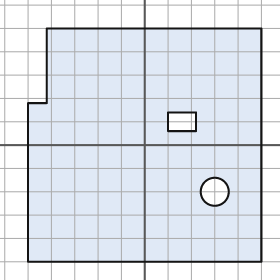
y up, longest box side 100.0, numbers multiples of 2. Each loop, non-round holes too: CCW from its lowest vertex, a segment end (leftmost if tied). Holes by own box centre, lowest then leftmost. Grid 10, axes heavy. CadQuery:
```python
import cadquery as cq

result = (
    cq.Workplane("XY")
    .moveTo(-50.0, -50.0)
    .lineTo(50.0, -50.0)
    .lineTo(50.0, 50.0)
    .lineTo(-42.0, 50.0)
    .lineTo(-42.0, 18.0)
    .lineTo(-50.0, 18.0)
    .close()
    .moveTo(30.0, -20.0)
    .circle(6.0)
    .moveTo(10.0, 6.0)
    .lineTo(22.0, 6.0)
    .lineTo(22.0, 14.0)
    .lineTo(10.0, 14.0)
    .close()
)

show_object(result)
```